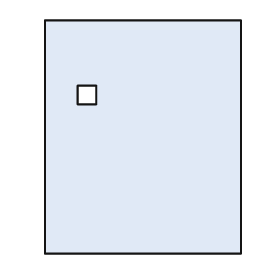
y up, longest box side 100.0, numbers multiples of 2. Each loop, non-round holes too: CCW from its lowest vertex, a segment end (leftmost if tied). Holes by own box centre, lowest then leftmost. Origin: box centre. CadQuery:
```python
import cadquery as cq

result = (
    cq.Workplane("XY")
    .moveTo(-42.0, -50.0)
    .lineTo(42.0, -50.0)
    .lineTo(42.0, 50.0)
    .lineTo(-42.0, 50.0)
    .close()
    .moveTo(-28.0, 14.0)
    .lineTo(-20.0, 14.0)
    .lineTo(-20.0, 22.0)
    .lineTo(-28.0, 22.0)
    .close()
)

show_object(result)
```